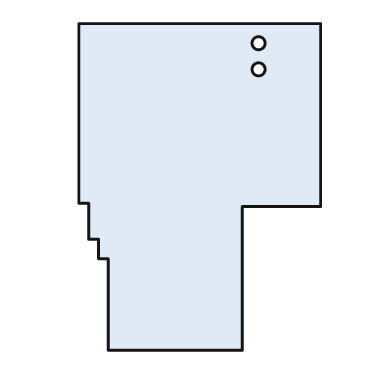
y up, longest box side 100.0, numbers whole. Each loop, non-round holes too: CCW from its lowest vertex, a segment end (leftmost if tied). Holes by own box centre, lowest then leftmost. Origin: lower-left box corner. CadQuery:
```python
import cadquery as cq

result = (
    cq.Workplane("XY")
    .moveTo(9.0, 0.0)
    .lineTo(50.0, 0.0)
    .lineTo(50.0, 44.0)
    .lineTo(74.0, 44.0)
    .lineTo(74.0, 100.0)
    .lineTo(0.0, 100.0)
    .lineTo(0.0, 45.0)
    .lineTo(3.0, 45.0)
    .lineTo(3.0, 34.0)
    .lineTo(6.0, 34.0)
    .lineTo(6.0, 28.0)
    .lineTo(9.0, 28.0)
    .close()
    .moveTo(55.0, 86.0)
    .circle(2.0)
    .moveTo(55.0, 94.0)
    .circle(2.0)
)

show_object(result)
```